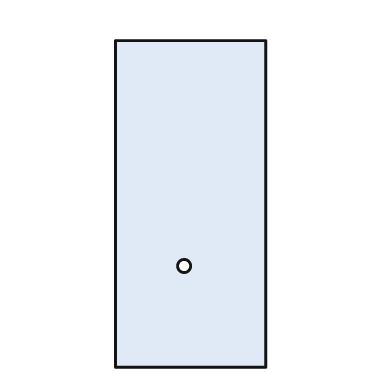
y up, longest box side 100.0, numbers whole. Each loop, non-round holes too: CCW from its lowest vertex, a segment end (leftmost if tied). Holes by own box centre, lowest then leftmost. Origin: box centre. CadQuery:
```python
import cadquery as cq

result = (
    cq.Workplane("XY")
    .moveTo(-23.0, -50.0)
    .lineTo(23.0, -50.0)
    .lineTo(23.0, 50.0)
    .lineTo(-23.0, 50.0)
    .close()
    .moveTo(-2.0, -19.0)
    .circle(2.0)
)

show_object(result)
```